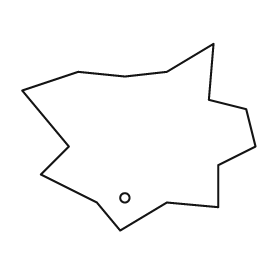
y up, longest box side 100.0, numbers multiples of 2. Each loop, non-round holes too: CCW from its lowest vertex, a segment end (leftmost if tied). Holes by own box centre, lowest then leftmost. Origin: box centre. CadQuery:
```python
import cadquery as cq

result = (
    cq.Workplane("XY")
    .moveTo(-8.0, -40.0)
    .lineTo(12.0, -28.0)
    .lineTo(34.0, -30.0)
    .lineTo(34.0, -12.0)
    .lineTo(50.0, -4.0)
    .lineTo(46.0, 12.0)
    .lineTo(30.0, 16.0)
    .lineTo(32.0, 40.0)
    .lineTo(12.0, 28.0)
    .lineTo(-6.0, 26.0)
    .lineTo(-26.0, 28.0)
    .lineTo(-50.0, 20.0)
    .lineTo(-30.0, -4.0)
    .lineTo(-42.0, -16.0)
    .lineTo(-18.0, -28.0)
    .close()
    .moveTo(-6.0, -26.0)
    .circle(2.0)
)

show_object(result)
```